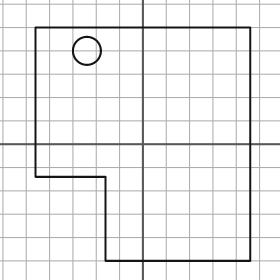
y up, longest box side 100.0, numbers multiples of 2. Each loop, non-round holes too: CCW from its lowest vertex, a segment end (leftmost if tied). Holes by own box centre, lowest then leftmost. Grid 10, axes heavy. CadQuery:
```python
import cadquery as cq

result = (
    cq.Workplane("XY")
    .moveTo(-16.0, -50.0)
    .lineTo(46.0, -50.0)
    .lineTo(46.0, 50.0)
    .lineTo(-46.0, 50.0)
    .lineTo(-46.0, -14.0)
    .lineTo(-16.0, -14.0)
    .close()
    .moveTo(-24.0, 40.0)
    .circle(6.0)
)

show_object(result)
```